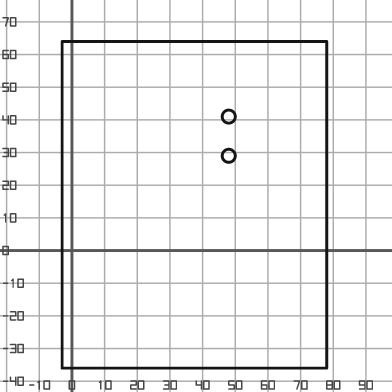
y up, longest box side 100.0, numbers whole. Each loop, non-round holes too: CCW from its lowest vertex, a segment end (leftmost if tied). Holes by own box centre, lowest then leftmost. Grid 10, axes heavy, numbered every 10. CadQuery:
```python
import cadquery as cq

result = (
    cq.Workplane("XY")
    .moveTo(-3.0, -36.0)
    .lineTo(78.0, -36.0)
    .lineTo(78.0, 64.0)
    .lineTo(-3.0, 64.0)
    .close()
    .moveTo(48.0, 29.0)
    .circle(2.0)
    .moveTo(48.0, 41.0)
    .circle(2.0)
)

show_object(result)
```